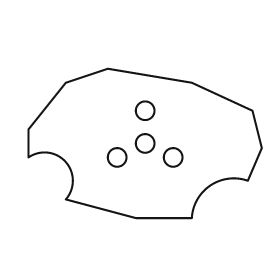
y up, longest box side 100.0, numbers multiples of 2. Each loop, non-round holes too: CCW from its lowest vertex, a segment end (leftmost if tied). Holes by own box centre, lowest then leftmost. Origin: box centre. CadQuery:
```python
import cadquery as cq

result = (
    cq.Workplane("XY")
    .moveTo(-4.0, -32.0)
    .lineTo(20.0, -32.0)
    .threePointArc((28.0, -18.0), (44.0, -16.0))
    .lineTo(50.0, -2.0)
    .lineTo(46.0, 14.0)
    .lineTo(20.0, 26.0)
    .lineTo(-16.0, 32.0)
    .lineTo(-34.0, 26.0)
    .lineTo(-50.0, 6.0)
    .lineTo(-50.0, -6.0)
    .threePointArc((-34.0, -8.0), (-34.0, -24.0))
    .close()
    .moveTo(-12.0, -6.0)
    .circle(4.0)
    .moveTo(12.0, -6.0)
    .circle(4.0)
    .moveTo(0.0, 0.0)
    .circle(4.0)
    .moveTo(0.0, 14.0)
    .circle(4.0)
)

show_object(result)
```